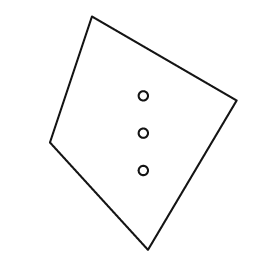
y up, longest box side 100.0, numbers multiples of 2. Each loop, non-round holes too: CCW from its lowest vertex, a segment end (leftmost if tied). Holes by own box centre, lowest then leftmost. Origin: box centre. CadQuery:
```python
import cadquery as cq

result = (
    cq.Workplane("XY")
    .moveTo(2.0, -50.0)
    .lineTo(40.0, 14.0)
    .lineTo(-22.0, 50.0)
    .lineTo(-40.0, -4.0)
    .close()
    .moveTo(0.0, -16.0)
    .circle(2.0)
    .moveTo(0.0, 0.0)
    .circle(2.0)
    .moveTo(0.0, 16.0)
    .circle(2.0)
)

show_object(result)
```